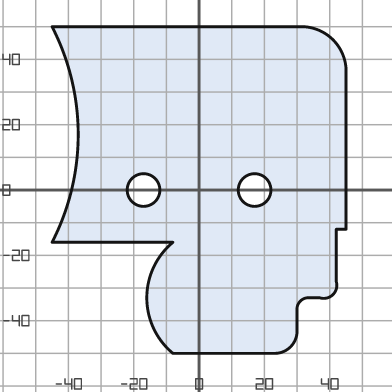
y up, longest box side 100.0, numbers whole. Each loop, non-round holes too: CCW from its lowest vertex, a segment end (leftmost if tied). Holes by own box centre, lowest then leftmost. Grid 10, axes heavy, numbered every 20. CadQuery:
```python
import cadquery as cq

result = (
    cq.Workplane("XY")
    .moveTo(-8.0, -50.0)
    .lineTo(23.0, -50.0)
    .threePointArc((28.0, -48.0), (30.0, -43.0))
    .lineTo(30.0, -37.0)
    .threePointArc((31.0, -34.0), (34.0, -33.0))
    .lineTo(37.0, -33.0)
    .threePointArc((41.0, -32.0), (42.0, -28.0))
    .lineTo(42.0, -12.0)
    .lineTo(45.0, -12.0)
    .lineTo(45.0, 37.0)
    .threePointArc((41.0, 46.0), (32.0, 50.0))
    .lineTo(-45.0, 50.0)
    .threePointArc((-37.0, 17.0), (-45.0, -16.0))
    .lineTo(-8.0, -16.0)
    .threePointArc((-16.0, -33.0), (-8.0, -50.0))
    .close()
    .moveTo(-17.0, 0.0)
    .circle(5.0)
    .moveTo(17.0, 0.0)
    .circle(5.0)
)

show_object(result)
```